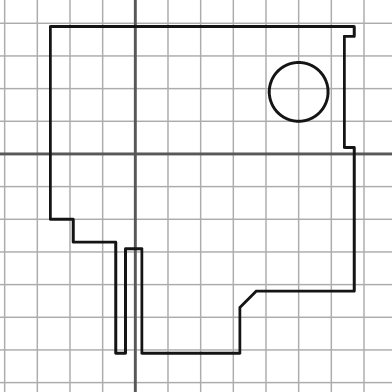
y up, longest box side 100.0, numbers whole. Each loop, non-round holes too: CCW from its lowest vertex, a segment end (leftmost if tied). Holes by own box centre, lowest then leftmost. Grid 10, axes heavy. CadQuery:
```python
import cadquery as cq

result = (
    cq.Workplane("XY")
    .moveTo(-6.0, -61.0)
    .lineTo(-3.0, -61.0)
    .lineTo(-3.0, -29.0)
    .lineTo(2.0, -29.0)
    .lineTo(2.0, -61.0)
    .lineTo(32.0, -61.0)
    .lineTo(32.0, -47.0)
    .lineTo(37.0, -42.0)
    .lineTo(67.0, -42.0)
    .lineTo(67.0, 2.0)
    .lineTo(64.0, 2.0)
    .lineTo(64.0, 36.0)
    .lineTo(67.0, 36.0)
    .lineTo(67.0, 39.0)
    .lineTo(-26.0, 39.0)
    .lineTo(-26.0, -20.0)
    .lineTo(-19.0, -20.0)
    .lineTo(-19.0, -27.0)
    .lineTo(-6.0, -27.0)
    .close()
    .moveTo(50.0, 19.0)
    .circle(9.0)
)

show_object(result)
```